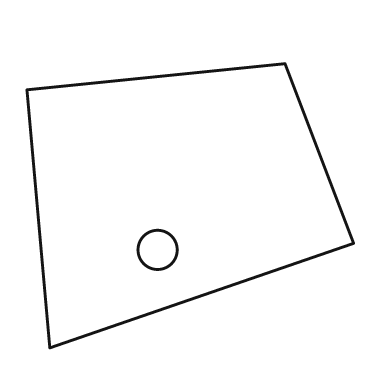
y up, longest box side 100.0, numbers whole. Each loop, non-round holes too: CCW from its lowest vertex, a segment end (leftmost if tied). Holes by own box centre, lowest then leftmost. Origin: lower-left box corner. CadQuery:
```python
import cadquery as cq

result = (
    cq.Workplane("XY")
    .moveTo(7.0, 0.0)
    .lineTo(100.0, 32.0)
    .lineTo(79.0, 87.0)
    .lineTo(0.0, 79.0)
    .close()
    .moveTo(40.0, 30.0)
    .circle(6.0)
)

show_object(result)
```